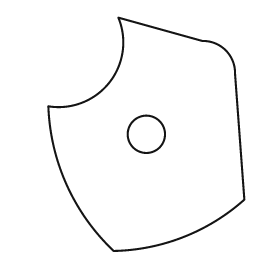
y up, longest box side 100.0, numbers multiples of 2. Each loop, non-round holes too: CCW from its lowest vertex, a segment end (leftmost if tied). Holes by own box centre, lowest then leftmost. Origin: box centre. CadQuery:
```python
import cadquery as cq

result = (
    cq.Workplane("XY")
    .moveTo(-14.0, -50.0)
    .threePointArc((16.0, -44.0), (42.0, -28.0))
    .lineTo(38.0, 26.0)
    .threePointArc((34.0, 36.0), (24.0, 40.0))
    .lineTo(-12.0, 50.0)
    .threePointArc((-16.0, 22.0), (-42.0, 12.0))
    .threePointArc((-34.0, -22.0), (-14.0, -50.0))
    .close()
    .moveTo(0.0, 0.0)
    .circle(8.0)
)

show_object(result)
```